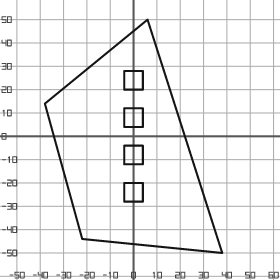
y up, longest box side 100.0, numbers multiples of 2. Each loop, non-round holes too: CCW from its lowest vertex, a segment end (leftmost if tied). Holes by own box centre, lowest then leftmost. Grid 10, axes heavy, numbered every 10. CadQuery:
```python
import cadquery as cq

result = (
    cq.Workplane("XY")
    .moveTo(38.0, -50.0)
    .lineTo(6.0, 50.0)
    .lineTo(-38.0, 14.0)
    .lineTo(-22.0, -44.0)
    .close()
    .moveTo(-4.0, -28.0)
    .lineTo(4.0, -28.0)
    .lineTo(4.0, -20.0)
    .lineTo(-4.0, -20.0)
    .close()
    .moveTo(-4.0, -12.0)
    .lineTo(4.0, -12.0)
    .lineTo(4.0, -4.0)
    .lineTo(-4.0, -4.0)
    .close()
    .moveTo(-4.0, 4.0)
    .lineTo(4.0, 4.0)
    .lineTo(4.0, 12.0)
    .lineTo(-4.0, 12.0)
    .close()
    .moveTo(-4.0, 20.0)
    .lineTo(4.0, 20.0)
    .lineTo(4.0, 28.0)
    .lineTo(-4.0, 28.0)
    .close()
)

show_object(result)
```